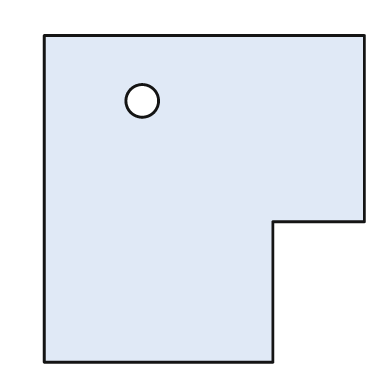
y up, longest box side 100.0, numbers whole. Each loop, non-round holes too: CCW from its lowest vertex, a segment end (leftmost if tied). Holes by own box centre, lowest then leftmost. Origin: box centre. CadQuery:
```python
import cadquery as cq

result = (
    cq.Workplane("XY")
    .moveTo(-49.0, -50.0)
    .lineTo(21.0, -50.0)
    .lineTo(21.0, -7.0)
    .lineTo(49.0, -7.0)
    .lineTo(49.0, 50.0)
    .lineTo(-49.0, 50.0)
    .close()
    .moveTo(-19.0, 30.0)
    .circle(5.0)
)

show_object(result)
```